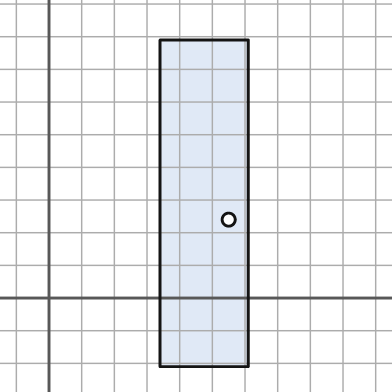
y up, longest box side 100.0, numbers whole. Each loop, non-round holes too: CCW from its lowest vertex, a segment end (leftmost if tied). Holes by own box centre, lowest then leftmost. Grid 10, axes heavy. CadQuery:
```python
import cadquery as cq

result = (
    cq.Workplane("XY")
    .moveTo(34.0, -21.0)
    .lineTo(61.0, -21.0)
    .lineTo(61.0, 79.0)
    .lineTo(34.0, 79.0)
    .close()
    .moveTo(55.0, 24.0)
    .circle(2.0)
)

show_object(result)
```